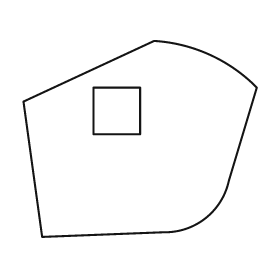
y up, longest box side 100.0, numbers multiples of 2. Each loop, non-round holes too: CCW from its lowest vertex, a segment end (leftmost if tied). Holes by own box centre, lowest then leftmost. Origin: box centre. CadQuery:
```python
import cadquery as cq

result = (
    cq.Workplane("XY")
    .moveTo(-42.0, -42.0)
    .lineTo(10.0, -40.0)
    .threePointArc((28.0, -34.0), (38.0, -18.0))
    .lineTo(50.0, 22.0)
    .threePointArc((30.0, 36.0), (6.0, 42.0))
    .lineTo(-50.0, 16.0)
    .close()
    .moveTo(-20.0, 2.0)
    .lineTo(0.0, 2.0)
    .lineTo(0.0, 22.0)
    .lineTo(-20.0, 22.0)
    .close()
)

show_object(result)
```